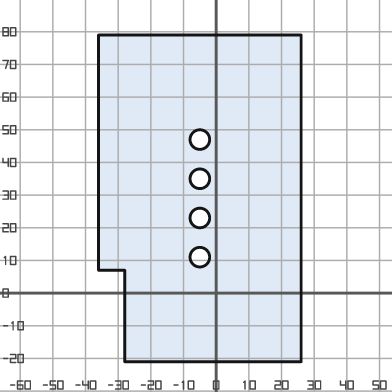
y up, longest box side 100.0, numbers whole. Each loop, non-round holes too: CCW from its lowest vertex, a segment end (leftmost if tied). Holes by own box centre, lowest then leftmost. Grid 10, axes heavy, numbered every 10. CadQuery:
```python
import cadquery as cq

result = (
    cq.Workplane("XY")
    .moveTo(-28.0, -21.0)
    .lineTo(26.0, -21.0)
    .lineTo(26.0, 79.0)
    .lineTo(-36.0, 79.0)
    .lineTo(-36.0, 7.0)
    .lineTo(-28.0, 7.0)
    .close()
    .moveTo(-5.0, 11.0)
    .circle(3.0)
    .moveTo(-5.0, 23.0)
    .circle(3.0)
    .moveTo(-5.0, 35.0)
    .circle(3.0)
    .moveTo(-5.0, 47.0)
    .circle(3.0)
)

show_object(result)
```